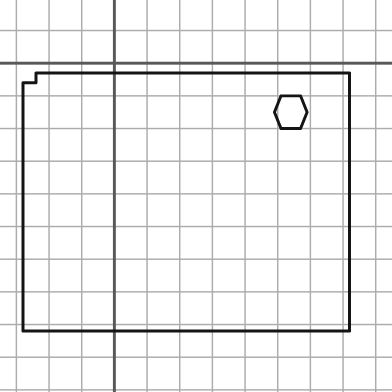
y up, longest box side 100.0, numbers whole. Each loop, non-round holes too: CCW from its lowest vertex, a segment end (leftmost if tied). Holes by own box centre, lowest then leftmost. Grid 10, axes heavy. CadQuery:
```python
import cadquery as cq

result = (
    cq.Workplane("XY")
    .moveTo(-28.0, -82.0)
    .lineTo(72.0, -82.0)
    .lineTo(72.0, -3.0)
    .lineTo(-24.0, -3.0)
    .lineTo(-24.0, -6.0)
    .lineTo(-28.0, -6.0)
    .close()
    .moveTo(51.0, -20.0)
    .lineTo(57.0, -20.0)
    .lineTo(59.0, -15.0)
    .lineTo(57.0, -10.0)
    .lineTo(51.0, -10.0)
    .lineTo(49.0, -15.0)
    .close()
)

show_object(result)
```